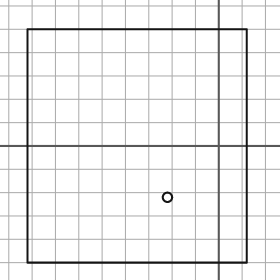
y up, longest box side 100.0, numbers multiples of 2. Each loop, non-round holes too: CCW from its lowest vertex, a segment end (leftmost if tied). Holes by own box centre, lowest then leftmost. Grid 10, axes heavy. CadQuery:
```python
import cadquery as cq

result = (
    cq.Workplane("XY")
    .moveTo(-82.0, -50.0)
    .lineTo(12.0, -50.0)
    .lineTo(12.0, 50.0)
    .lineTo(-82.0, 50.0)
    .close()
    .moveTo(-22.0, -22.0)
    .circle(2.0)
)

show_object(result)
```